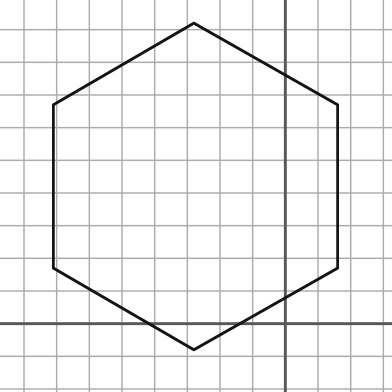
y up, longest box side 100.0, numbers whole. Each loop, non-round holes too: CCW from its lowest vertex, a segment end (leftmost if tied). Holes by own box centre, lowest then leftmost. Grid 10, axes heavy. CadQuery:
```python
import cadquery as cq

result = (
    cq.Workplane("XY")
    .moveTo(-28.0, -8.0)
    .lineTo(16.0, 17.0)
    .lineTo(16.0, 67.0)
    .lineTo(-28.0, 92.0)
    .lineTo(-71.0, 67.0)
    .lineTo(-71.0, 17.0)
    .close()
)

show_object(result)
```